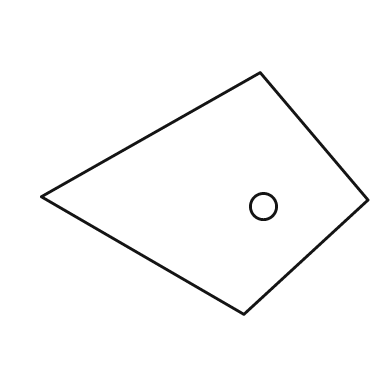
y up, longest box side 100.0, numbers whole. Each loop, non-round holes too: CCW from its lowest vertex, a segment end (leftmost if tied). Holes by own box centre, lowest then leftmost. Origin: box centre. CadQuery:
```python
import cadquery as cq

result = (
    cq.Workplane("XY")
    .moveTo(12.0, -37.0)
    .lineTo(50.0, -2.0)
    .lineTo(17.0, 37.0)
    .lineTo(-50.0, -1.0)
    .close()
    .moveTo(18.0, -4.0)
    .circle(4.0)
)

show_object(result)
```